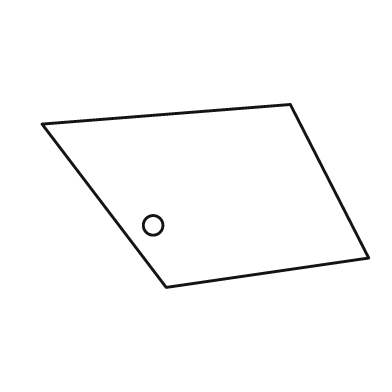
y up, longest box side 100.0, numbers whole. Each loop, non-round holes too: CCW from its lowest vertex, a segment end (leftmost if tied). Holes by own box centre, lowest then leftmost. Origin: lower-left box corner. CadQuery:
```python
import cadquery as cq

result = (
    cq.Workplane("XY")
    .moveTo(38.0, 0.0)
    .lineTo(100.0, 9.0)
    .lineTo(76.0, 56.0)
    .lineTo(0.0, 50.0)
    .close()
    .moveTo(34.0, 19.0)
    .circle(3.0)
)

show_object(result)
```